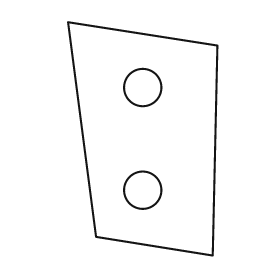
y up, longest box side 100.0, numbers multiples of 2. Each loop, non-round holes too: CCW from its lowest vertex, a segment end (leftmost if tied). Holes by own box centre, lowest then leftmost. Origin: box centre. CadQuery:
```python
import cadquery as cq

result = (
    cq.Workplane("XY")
    .moveTo(30.0, -50.0)
    .lineTo(32.0, 40.0)
    .lineTo(-32.0, 50.0)
    .lineTo(-20.0, -42.0)
    .close()
    .moveTo(0.0, -22.0)
    .circle(8.0)
    .moveTo(0.0, 22.0)
    .circle(8.0)
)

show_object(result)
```